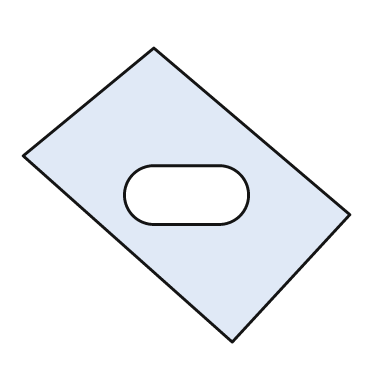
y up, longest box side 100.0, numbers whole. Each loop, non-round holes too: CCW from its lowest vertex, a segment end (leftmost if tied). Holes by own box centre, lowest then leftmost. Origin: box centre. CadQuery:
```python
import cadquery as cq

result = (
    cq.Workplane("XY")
    .moveTo(14.0, -45.0)
    .lineTo(50.0, -6.0)
    .lineTo(-10.0, 45.0)
    .lineTo(-50.0, 12.0)
    .close()
    .moveTo(-10.0, -9.0)
    .lineTo(10.0, -9.0)
    .threePointArc((19.0, 0.0), (10.0, 9.0))
    .lineTo(-10.0, 9.0)
    .threePointArc((-19.0, 0.0), (-10.0, -9.0))
    .close()
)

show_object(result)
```